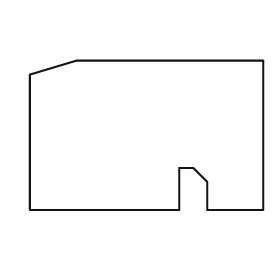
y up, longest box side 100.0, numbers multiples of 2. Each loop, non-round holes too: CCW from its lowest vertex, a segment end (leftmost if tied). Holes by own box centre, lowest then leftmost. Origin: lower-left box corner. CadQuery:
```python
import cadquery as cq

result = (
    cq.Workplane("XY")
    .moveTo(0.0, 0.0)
    .lineTo(64.0, 0.0)
    .lineTo(64.0, 18.0)
    .lineTo(70.0, 18.0)
    .lineTo(76.0, 12.0)
    .lineTo(76.0, 0.0)
    .lineTo(100.0, 0.0)
    .lineTo(100.0, 64.0)
    .lineTo(20.0, 64.0)
    .lineTo(0.0, 58.0)
    .close()
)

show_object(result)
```